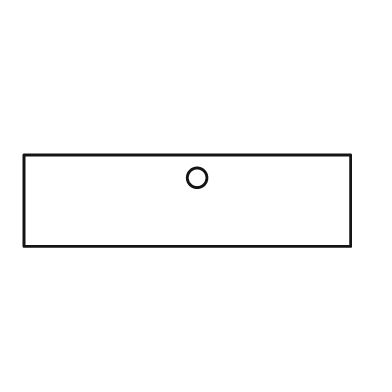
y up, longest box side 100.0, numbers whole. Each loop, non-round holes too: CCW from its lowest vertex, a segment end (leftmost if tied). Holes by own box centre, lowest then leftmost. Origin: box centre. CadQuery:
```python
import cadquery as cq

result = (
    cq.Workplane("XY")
    .moveTo(-50.0, -14.0)
    .lineTo(50.0, -14.0)
    .lineTo(50.0, 14.0)
    .lineTo(-50.0, 14.0)
    .close()
    .moveTo(3.0, 7.0)
    .circle(3.0)
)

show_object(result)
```